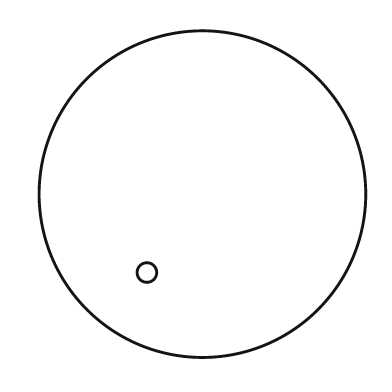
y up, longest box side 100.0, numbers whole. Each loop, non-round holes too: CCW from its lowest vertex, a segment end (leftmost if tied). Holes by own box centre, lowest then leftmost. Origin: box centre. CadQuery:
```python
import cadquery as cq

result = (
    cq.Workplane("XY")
    .moveTo(0.0, 0.0)
    .circle(50.0)
    .moveTo(-17.0, -24.0)
    .circle(3.0)
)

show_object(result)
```